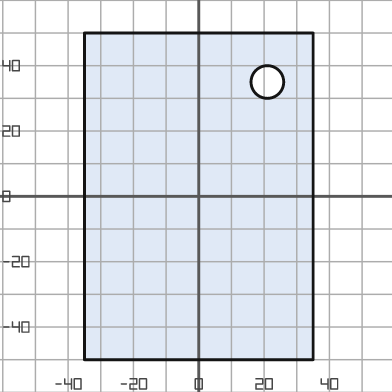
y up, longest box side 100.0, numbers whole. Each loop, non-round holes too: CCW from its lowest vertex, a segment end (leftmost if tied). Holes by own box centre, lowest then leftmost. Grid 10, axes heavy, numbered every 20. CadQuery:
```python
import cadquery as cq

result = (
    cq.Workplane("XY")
    .moveTo(-35.0, -50.0)
    .lineTo(35.0, -50.0)
    .lineTo(35.0, 50.0)
    .lineTo(-35.0, 50.0)
    .close()
    .moveTo(21.0, 35.0)
    .circle(5.0)
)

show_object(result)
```